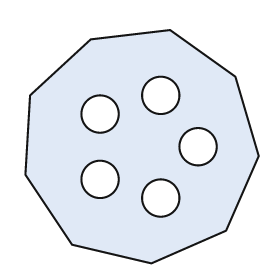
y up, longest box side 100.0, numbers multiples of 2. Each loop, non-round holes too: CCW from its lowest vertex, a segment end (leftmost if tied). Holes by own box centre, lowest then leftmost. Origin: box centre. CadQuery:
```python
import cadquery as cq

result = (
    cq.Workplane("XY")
    .moveTo(4.0, -50.0)
    .lineTo(36.0, -36.0)
    .lineTo(50.0, -4.0)
    .lineTo(40.0, 30.0)
    .lineTo(12.0, 50.0)
    .lineTo(-22.0, 46.0)
    .lineTo(-48.0, 22.0)
    .lineTo(-50.0, -12.0)
    .lineTo(-30.0, -42.0)
    .close()
    .moveTo(8.0, -22.0)
    .circle(8.0)
    .moveTo(-18.0, -14.0)
    .circle(8.0)
    .moveTo(24.0, 0.0)
    .circle(8.0)
    .moveTo(-18.0, 14.0)
    .circle(8.0)
    .moveTo(8.0, 22.0)
    .circle(8.0)
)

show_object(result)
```